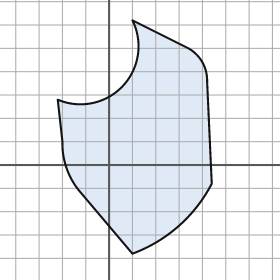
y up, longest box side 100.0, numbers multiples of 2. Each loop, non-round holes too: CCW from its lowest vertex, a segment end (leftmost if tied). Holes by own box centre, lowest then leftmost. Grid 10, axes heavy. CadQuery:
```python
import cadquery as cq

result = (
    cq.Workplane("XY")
    .moveTo(10.0, -38.0)
    .threePointArc((30.0, -26.0), (44.0, -8.0))
    .lineTo(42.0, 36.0)
    .threePointArc((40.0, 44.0), (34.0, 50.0))
    .lineTo(10.0, 62.0)
    .threePointArc((6.0, 34.0), (-22.0, 28.0))
    .lineTo(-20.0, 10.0)
    .threePointArc((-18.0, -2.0), (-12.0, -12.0))
    .close()
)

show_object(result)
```